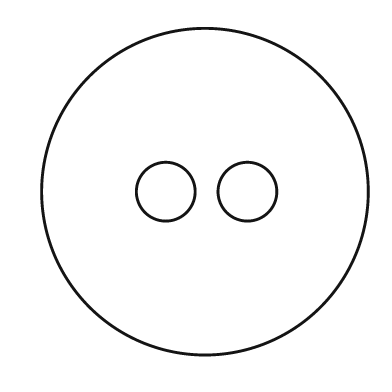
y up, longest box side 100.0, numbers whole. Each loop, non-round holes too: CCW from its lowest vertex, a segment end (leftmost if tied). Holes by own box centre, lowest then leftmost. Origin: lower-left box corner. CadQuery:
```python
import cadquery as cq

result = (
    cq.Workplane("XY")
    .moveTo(50.0, 50.0)
    .circle(50.0)
    .moveTo(38.0, 50.0)
    .circle(9.0)
    .moveTo(63.0, 50.0)
    .circle(9.0)
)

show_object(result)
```